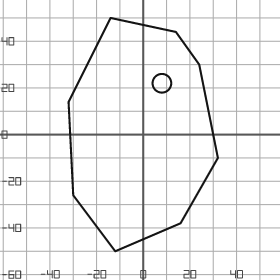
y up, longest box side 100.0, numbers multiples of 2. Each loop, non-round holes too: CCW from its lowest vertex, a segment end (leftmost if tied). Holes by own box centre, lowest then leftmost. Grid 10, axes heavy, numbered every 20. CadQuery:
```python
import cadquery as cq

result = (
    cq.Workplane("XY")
    .moveTo(-12.0, -50.0)
    .lineTo(16.0, -38.0)
    .lineTo(32.0, -10.0)
    .lineTo(24.0, 30.0)
    .lineTo(14.0, 44.0)
    .lineTo(-14.0, 50.0)
    .lineTo(-32.0, 14.0)
    .lineTo(-30.0, -26.0)
    .close()
    .moveTo(8.0, 22.0)
    .circle(4.0)
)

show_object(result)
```